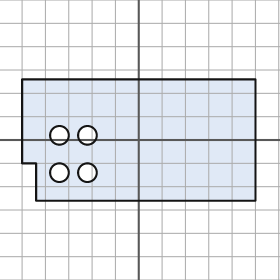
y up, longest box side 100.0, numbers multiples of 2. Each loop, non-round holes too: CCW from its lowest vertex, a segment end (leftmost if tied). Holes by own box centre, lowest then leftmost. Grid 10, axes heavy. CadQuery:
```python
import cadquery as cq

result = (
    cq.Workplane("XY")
    .moveTo(-44.0, -26.0)
    .lineTo(50.0, -26.0)
    .lineTo(50.0, 26.0)
    .lineTo(-50.0, 26.0)
    .lineTo(-50.0, -10.0)
    .lineTo(-44.0, -10.0)
    .close()
    .moveTo(-34.0, -14.0)
    .circle(4.0)
    .moveTo(-22.0, -14.0)
    .circle(4.0)
    .moveTo(-34.0, 2.0)
    .circle(4.0)
    .moveTo(-22.0, 2.0)
    .circle(4.0)
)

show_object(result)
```